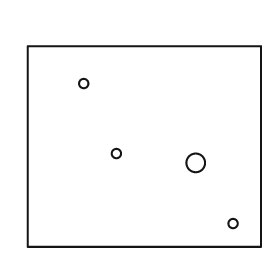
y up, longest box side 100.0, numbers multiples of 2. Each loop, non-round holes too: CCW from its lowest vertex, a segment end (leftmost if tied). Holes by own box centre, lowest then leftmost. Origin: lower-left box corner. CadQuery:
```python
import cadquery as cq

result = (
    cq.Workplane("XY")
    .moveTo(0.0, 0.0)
    .lineTo(100.0, 0.0)
    .lineTo(100.0, 86.0)
    .lineTo(0.0, 86.0)
    .close()
    .moveTo(88.0, 10.0)
    .circle(2.0)
    .moveTo(72.0, 36.0)
    .circle(4.0)
    .moveTo(38.0, 40.0)
    .circle(2.0)
    .moveTo(24.0, 70.0)
    .circle(2.0)
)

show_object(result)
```